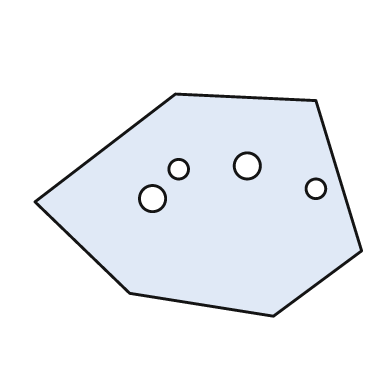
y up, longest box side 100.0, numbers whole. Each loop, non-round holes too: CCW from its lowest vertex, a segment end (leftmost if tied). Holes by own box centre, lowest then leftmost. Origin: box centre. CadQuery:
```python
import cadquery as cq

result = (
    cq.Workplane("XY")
    .moveTo(23.0, -34.0)
    .lineTo(50.0, -14.0)
    .lineTo(36.0, 32.0)
    .lineTo(-7.0, 34.0)
    .lineTo(-50.0, 1.0)
    .lineTo(-21.0, -27.0)
    .close()
    .moveTo(-14.0, 2.0)
    .circle(4.0)
    .moveTo(36.0, 5.0)
    .circle(3.0)
    .moveTo(-6.0, 11.0)
    .circle(3.0)
    .moveTo(15.0, 12.0)
    .circle(4.0)
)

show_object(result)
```